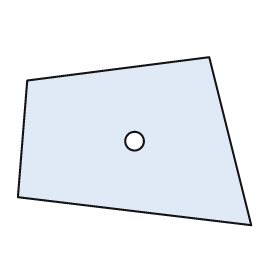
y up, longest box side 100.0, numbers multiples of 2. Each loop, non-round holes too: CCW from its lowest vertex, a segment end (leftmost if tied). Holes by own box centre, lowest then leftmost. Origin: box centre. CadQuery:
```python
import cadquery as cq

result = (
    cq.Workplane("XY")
    .moveTo(50.0, -36.0)
    .lineTo(32.0, 36.0)
    .lineTo(-46.0, 26.0)
    .lineTo(-50.0, -24.0)
    .close()
    .moveTo(0.0, 0.0)
    .circle(4.0)
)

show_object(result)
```